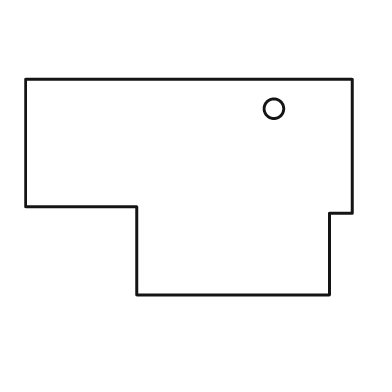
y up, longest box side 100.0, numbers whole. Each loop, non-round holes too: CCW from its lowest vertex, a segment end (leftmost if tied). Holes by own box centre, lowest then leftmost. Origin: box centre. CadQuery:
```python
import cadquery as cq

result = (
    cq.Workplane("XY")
    .moveTo(-16.0, -33.0)
    .lineTo(43.0, -33.0)
    .lineTo(43.0, -8.0)
    .lineTo(50.0, -8.0)
    .lineTo(50.0, 33.0)
    .lineTo(-50.0, 33.0)
    .lineTo(-50.0, -6.0)
    .lineTo(-16.0, -6.0)
    .close()
    .moveTo(26.0, 24.0)
    .circle(3.0)
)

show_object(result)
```